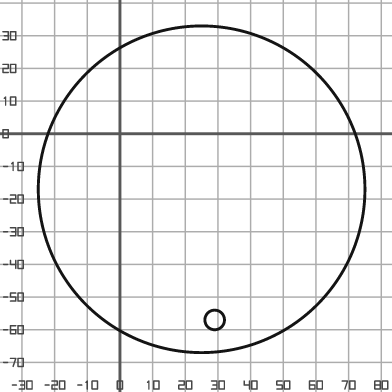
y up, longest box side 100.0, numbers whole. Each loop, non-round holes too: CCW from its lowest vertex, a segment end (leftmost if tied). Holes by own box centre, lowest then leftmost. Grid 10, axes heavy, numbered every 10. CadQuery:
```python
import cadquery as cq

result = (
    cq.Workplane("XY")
    .moveTo(25.0, -17.0)
    .circle(50.0)
    .moveTo(29.0, -57.0)
    .circle(3.0)
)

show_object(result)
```